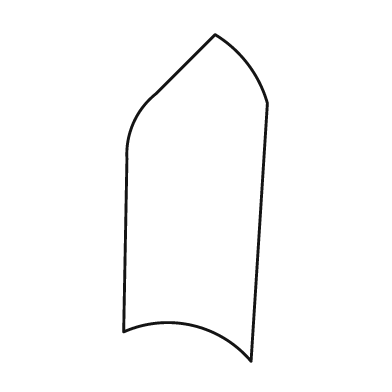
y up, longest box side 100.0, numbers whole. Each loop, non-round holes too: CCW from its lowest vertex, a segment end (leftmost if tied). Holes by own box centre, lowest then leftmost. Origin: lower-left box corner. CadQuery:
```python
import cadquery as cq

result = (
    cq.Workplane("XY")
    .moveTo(39.0, 0.0)
    .lineTo(44.0, 79.0)
    .threePointArc((38.0, 91.0), (28.0, 100.0))
    .lineTo(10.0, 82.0)
    .threePointArc((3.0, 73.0), (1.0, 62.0))
    .lineTo(0.0, 9.0)
    .threePointArc((21.0, 11.0), (39.0, 0.0))
    .close()
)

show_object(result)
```